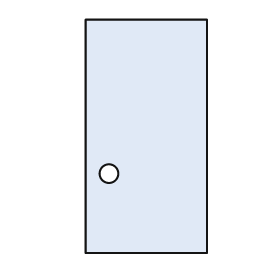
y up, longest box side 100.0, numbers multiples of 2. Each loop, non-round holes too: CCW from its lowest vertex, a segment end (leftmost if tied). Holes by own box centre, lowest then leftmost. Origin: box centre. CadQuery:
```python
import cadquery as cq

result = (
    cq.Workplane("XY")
    .moveTo(-26.0, -50.0)
    .lineTo(26.0, -50.0)
    .lineTo(26.0, 50.0)
    .lineTo(-26.0, 50.0)
    .close()
    .moveTo(-16.0, -16.0)
    .circle(4.0)
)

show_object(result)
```